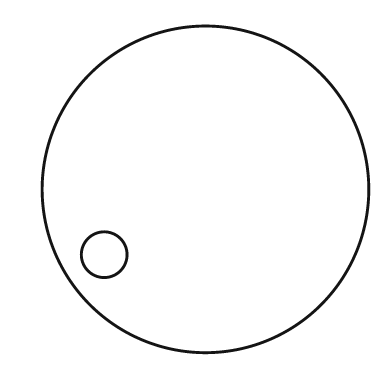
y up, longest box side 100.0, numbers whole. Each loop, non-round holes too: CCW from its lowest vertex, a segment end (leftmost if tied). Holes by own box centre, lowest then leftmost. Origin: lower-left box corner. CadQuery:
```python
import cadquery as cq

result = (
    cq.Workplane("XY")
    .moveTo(50.0, 50.0)
    .circle(50.0)
    .moveTo(19.0, 30.0)
    .circle(7.0)
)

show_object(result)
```